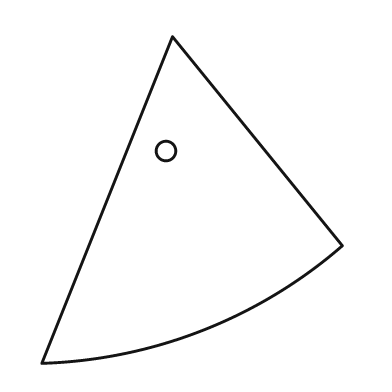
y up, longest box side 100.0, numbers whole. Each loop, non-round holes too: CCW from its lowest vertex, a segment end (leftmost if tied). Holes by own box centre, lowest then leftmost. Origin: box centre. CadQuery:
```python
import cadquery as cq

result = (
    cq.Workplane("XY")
    .moveTo(-46.0, -50.0)
    .threePointArc((3.0, -40.0), (46.0, -14.0))
    .lineTo(-6.0, 50.0)
    .close()
    .moveTo(-8.0, 15.0)
    .circle(3.0)
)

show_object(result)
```